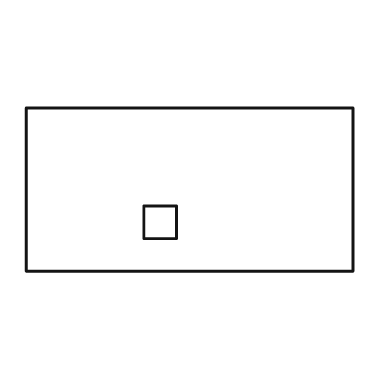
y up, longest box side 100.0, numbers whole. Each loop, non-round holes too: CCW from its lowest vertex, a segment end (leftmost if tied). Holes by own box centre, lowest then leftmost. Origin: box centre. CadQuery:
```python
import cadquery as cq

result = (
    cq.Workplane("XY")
    .moveTo(-50.0, -25.0)
    .lineTo(50.0, -25.0)
    .lineTo(50.0, 25.0)
    .lineTo(-50.0, 25.0)
    .close()
    .moveTo(-14.0, -15.0)
    .lineTo(-4.0, -15.0)
    .lineTo(-4.0, -5.0)
    .lineTo(-14.0, -5.0)
    .close()
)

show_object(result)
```